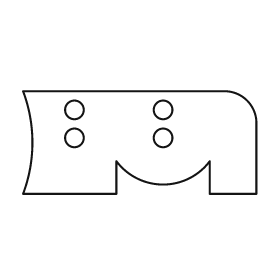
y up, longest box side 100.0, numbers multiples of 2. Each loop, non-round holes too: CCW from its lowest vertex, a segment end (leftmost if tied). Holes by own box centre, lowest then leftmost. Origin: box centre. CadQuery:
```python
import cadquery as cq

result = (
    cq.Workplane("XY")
    .moveTo(-50.0, -22.0)
    .lineTo(-10.0, -22.0)
    .lineTo(-10.0, -8.0)
    .threePointArc((10.0, -18.0), (30.0, -8.0))
    .lineTo(30.0, -22.0)
    .lineTo(50.0, -22.0)
    .lineTo(50.0, 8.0)
    .threePointArc((46.0, 18.0), (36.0, 22.0))
    .lineTo(-50.0, 22.0)
    .threePointArc((-46.0, 0.0), (-50.0, -22.0))
    .close()
    .moveTo(-28.0, 2.0)
    .circle(4.0)
    .moveTo(10.0, 2.0)
    .circle(4.0)
    .moveTo(-28.0, 14.0)
    .circle(4.0)
    .moveTo(10.0, 14.0)
    .circle(4.0)
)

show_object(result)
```